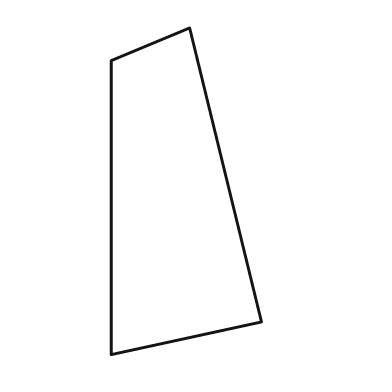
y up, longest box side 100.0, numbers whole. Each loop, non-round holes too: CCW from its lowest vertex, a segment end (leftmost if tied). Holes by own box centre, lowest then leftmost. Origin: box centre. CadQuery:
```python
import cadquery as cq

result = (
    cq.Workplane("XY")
    .moveTo(-23.0, -50.0)
    .lineTo(23.0, -40.0)
    .lineTo(1.0, 50.0)
    .lineTo(-23.0, 40.0)
    .close()
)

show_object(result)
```